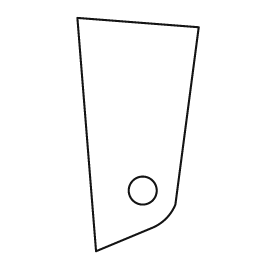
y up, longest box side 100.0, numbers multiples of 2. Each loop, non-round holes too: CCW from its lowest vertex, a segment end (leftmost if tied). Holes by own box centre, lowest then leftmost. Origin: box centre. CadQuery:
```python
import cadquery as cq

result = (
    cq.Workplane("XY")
    .moveTo(-18.0, -50.0)
    .lineTo(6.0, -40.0)
    .threePointArc((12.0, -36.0), (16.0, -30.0))
    .lineTo(26.0, 46.0)
    .lineTo(-26.0, 50.0)
    .close()
    .moveTo(2.0, -24.0)
    .circle(6.0)
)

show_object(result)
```